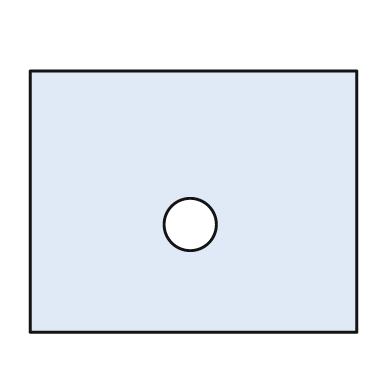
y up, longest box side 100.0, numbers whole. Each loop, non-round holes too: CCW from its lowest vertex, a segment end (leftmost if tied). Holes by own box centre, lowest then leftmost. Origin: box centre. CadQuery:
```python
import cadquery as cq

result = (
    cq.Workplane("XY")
    .moveTo(-50.0, -40.0)
    .lineTo(50.0, -40.0)
    .lineTo(50.0, 40.0)
    .lineTo(-50.0, 40.0)
    .close()
    .moveTo(-1.0, -7.0)
    .circle(8.0)
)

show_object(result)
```